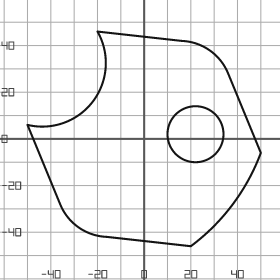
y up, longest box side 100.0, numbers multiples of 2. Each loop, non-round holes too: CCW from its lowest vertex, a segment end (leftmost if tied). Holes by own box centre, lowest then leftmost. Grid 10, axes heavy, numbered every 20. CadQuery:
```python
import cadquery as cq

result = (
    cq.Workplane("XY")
    .moveTo(20.0, -46.0)
    .threePointArc((38.0, -28.0), (50.0, -6.0))
    .lineTo(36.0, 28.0)
    .threePointArc((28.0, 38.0), (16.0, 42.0))
    .lineTo(-20.0, 46.0)
    .threePointArc((-22.0, 16.0), (-50.0, 6.0))
    .lineTo(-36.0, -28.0)
    .threePointArc((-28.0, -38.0), (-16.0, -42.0))
    .close()
    .moveTo(22.0, 2.0)
    .circle(12.0)
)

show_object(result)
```